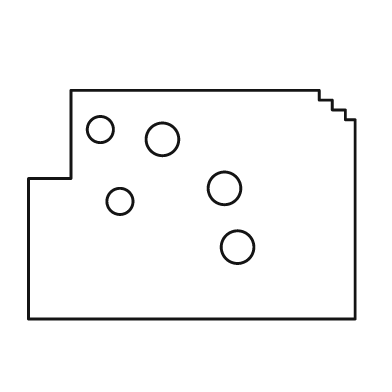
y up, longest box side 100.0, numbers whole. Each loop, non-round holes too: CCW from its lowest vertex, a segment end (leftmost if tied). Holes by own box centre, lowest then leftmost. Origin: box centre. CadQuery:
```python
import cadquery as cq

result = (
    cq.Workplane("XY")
    .moveTo(-50.0, -35.0)
    .lineTo(50.0, -35.0)
    .lineTo(50.0, 26.0)
    .lineTo(47.0, 26.0)
    .lineTo(47.0, 29.0)
    .lineTo(43.0, 29.0)
    .lineTo(43.0, 32.0)
    .lineTo(39.0, 32.0)
    .lineTo(39.0, 35.0)
    .lineTo(-37.0, 35.0)
    .lineTo(-37.0, 8.0)
    .lineTo(-50.0, 8.0)
    .close()
    .moveTo(14.0, -13.0)
    .circle(5.0)
    .moveTo(-22.0, 1.0)
    .circle(4.0)
    .moveTo(10.0, 5.0)
    .circle(5.0)
    .moveTo(-9.0, 20.0)
    .circle(5.0)
    .moveTo(-28.0, 23.0)
    .circle(4.0)
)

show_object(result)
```